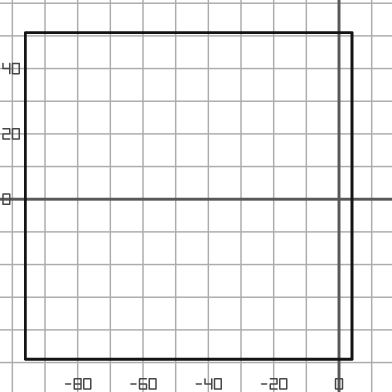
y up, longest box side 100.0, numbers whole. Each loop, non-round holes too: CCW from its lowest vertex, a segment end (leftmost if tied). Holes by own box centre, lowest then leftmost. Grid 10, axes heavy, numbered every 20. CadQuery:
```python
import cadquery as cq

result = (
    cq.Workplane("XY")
    .moveTo(-96.0, -49.0)
    .lineTo(4.0, -49.0)
    .lineTo(4.0, 51.0)
    .lineTo(-96.0, 51.0)
    .close()
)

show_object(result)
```